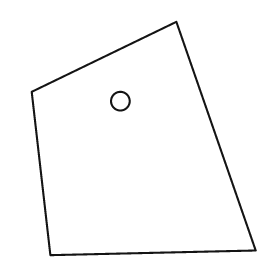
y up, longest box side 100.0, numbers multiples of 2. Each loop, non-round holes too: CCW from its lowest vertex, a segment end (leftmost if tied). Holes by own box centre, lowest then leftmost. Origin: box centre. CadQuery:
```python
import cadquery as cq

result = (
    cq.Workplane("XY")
    .moveTo(-40.0, -50.0)
    .lineTo(48.0, -48.0)
    .lineTo(14.0, 50.0)
    .lineTo(-48.0, 20.0)
    .close()
    .moveTo(-10.0, 16.0)
    .circle(4.0)
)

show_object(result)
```